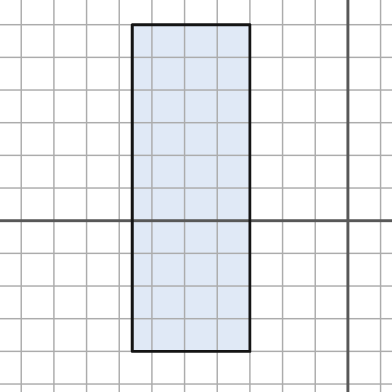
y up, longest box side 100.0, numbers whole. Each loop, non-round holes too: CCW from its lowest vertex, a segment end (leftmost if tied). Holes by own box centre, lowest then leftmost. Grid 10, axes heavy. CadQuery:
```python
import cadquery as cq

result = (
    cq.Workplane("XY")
    .moveTo(-66.0, -40.0)
    .lineTo(-30.0, -40.0)
    .lineTo(-30.0, 60.0)
    .lineTo(-66.0, 60.0)
    .close()
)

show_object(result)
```